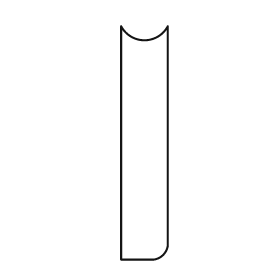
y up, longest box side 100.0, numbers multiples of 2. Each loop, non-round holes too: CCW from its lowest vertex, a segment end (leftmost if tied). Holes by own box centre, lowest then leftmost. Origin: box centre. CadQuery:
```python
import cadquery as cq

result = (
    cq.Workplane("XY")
    .moveTo(-10.0, -50.0)
    .lineTo(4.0, -50.0)
    .threePointArc((8.0, -48.0), (10.0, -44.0))
    .lineTo(10.0, 50.0)
    .threePointArc((0.0, 44.0), (-10.0, 50.0))
    .close()
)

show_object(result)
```